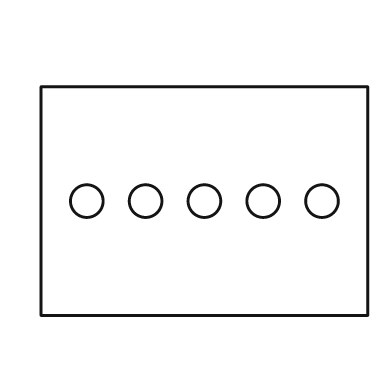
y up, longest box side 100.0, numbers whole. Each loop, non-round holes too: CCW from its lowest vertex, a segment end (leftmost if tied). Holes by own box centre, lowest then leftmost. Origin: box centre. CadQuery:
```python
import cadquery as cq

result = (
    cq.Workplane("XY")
    .moveTo(-50.0, -35.0)
    .lineTo(50.0, -35.0)
    .lineTo(50.0, 35.0)
    .lineTo(-50.0, 35.0)
    .close()
    .moveTo(-36.0, 0.0)
    .circle(5.0)
    .moveTo(-18.0, 0.0)
    .circle(5.0)
    .moveTo(0.0, 0.0)
    .circle(5.0)
    .moveTo(18.0, 0.0)
    .circle(5.0)
    .moveTo(36.0, 0.0)
    .circle(5.0)
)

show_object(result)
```